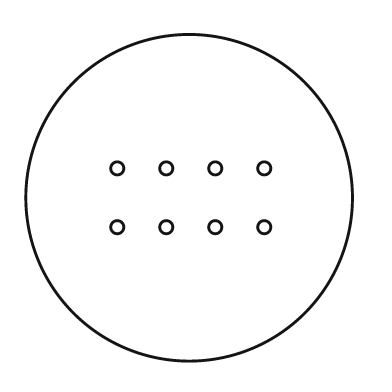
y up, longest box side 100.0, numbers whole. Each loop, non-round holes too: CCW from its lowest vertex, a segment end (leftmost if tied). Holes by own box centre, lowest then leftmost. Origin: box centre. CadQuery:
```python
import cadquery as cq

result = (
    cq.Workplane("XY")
    .moveTo(0.0, 0.0)
    .circle(50.0)
    .moveTo(-22.0, -9.0)
    .circle(2.0)
    .moveTo(-7.0, -9.0)
    .circle(2.0)
    .moveTo(8.0, -9.0)
    .circle(2.0)
    .moveTo(23.0, -9.0)
    .circle(2.0)
    .moveTo(-22.0, 9.0)
    .circle(2.0)
    .moveTo(-7.0, 9.0)
    .circle(2.0)
    .moveTo(8.0, 9.0)
    .circle(2.0)
    .moveTo(23.0, 9.0)
    .circle(2.0)
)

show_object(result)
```